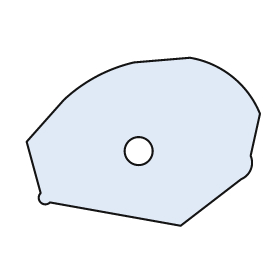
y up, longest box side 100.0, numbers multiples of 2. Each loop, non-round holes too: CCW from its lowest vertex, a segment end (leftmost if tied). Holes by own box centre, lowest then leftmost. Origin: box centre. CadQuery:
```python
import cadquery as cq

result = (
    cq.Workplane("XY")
    .moveTo(16.0, -36.0)
    .lineTo(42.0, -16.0)
    .threePointArc((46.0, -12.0), (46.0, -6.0))
    .lineTo(50.0, 12.0)
    .threePointArc((38.0, 28.0), (20.0, 36.0))
    .lineTo(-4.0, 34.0)
    .threePointArc((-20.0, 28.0), (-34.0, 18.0))
    .lineTo(-50.0, 0.0)
    .lineTo(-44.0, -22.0)
    .threePointArc((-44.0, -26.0), (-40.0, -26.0))
    .close()
    .moveTo(-2.0, -4.0)
    .circle(6.0)
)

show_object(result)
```